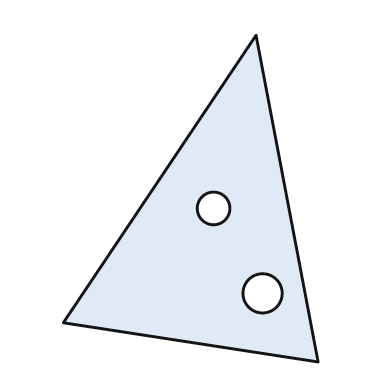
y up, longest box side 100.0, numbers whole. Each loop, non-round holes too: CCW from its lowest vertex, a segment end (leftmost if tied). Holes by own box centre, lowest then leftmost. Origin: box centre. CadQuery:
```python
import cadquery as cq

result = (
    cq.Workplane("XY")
    .moveTo(39.0, -50.0)
    .lineTo(20.0, 50.0)
    .lineTo(-39.0, -38.0)
    .close()
    .moveTo(22.0, -29.0)
    .circle(6.0)
    .moveTo(7.0, -3.0)
    .circle(5.0)
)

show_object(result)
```